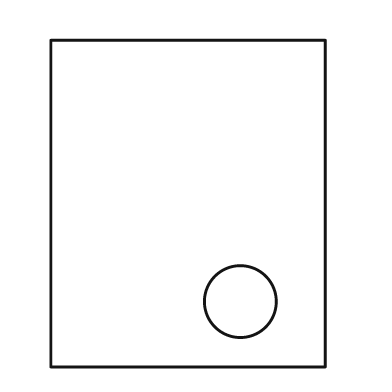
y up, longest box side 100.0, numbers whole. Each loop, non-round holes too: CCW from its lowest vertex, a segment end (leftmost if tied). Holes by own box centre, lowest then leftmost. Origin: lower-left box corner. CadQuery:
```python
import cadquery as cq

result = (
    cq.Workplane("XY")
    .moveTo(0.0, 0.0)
    .lineTo(84.0, 0.0)
    .lineTo(84.0, 100.0)
    .lineTo(0.0, 100.0)
    .close()
    .moveTo(58.0, 20.0)
    .circle(11.0)
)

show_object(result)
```